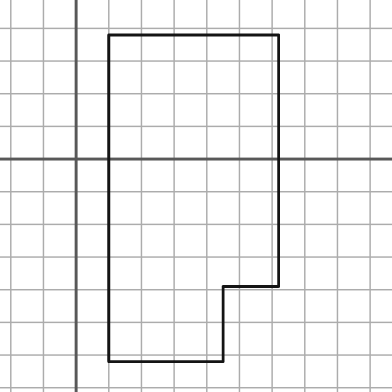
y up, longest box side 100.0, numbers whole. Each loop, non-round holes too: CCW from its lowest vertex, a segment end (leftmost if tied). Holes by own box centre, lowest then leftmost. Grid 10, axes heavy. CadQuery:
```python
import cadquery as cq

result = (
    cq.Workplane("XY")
    .moveTo(10.0, -62.0)
    .lineTo(45.0, -62.0)
    .lineTo(45.0, -39.0)
    .lineTo(62.0, -39.0)
    .lineTo(62.0, 38.0)
    .lineTo(10.0, 38.0)
    .close()
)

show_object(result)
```